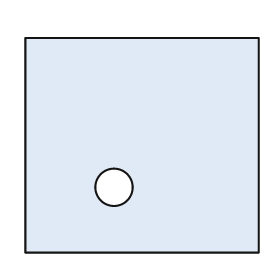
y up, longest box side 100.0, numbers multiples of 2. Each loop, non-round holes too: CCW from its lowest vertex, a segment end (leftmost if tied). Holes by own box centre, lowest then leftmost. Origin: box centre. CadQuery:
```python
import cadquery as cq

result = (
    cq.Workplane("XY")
    .moveTo(-50.0, -46.0)
    .lineTo(50.0, -46.0)
    .lineTo(50.0, 46.0)
    .lineTo(-50.0, 46.0)
    .close()
    .moveTo(-12.0, -18.0)
    .circle(8.0)
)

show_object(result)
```